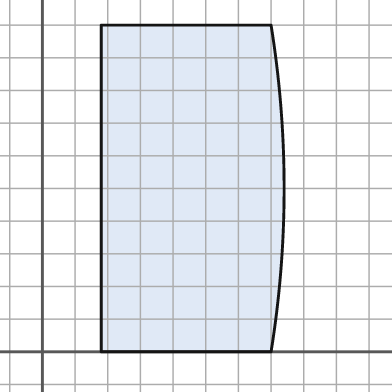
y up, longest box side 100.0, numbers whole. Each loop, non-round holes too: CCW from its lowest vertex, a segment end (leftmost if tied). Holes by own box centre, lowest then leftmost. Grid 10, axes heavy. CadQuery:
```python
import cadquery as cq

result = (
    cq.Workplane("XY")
    .moveTo(18.0, 0.0)
    .lineTo(70.0, 0.0)
    .threePointArc((74.0, 50.0), (70.0, 100.0))
    .lineTo(18.0, 100.0)
    .close()
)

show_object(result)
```